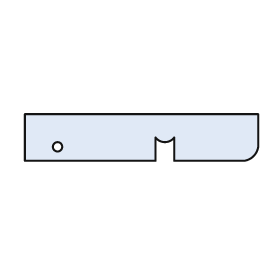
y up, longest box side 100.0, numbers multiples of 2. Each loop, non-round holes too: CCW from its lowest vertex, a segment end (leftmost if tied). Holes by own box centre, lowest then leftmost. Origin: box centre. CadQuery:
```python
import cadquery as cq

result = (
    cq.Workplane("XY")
    .moveTo(-50.0, -10.0)
    .lineTo(6.0, -10.0)
    .lineTo(6.0, 0.0)
    .threePointArc((10.0, -2.0), (14.0, 0.0))
    .lineTo(14.0, -10.0)
    .lineTo(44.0, -10.0)
    .threePointArc((48.0, -8.0), (50.0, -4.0))
    .lineTo(50.0, 10.0)
    .lineTo(-50.0, 10.0)
    .close()
    .moveTo(-36.0, -4.0)
    .circle(2.0)
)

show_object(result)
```